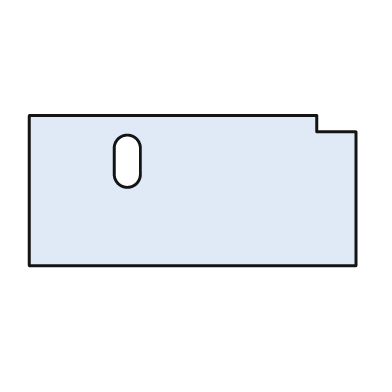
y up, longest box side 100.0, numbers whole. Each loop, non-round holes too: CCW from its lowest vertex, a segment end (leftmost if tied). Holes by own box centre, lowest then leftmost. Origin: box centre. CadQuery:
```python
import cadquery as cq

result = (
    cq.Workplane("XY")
    .moveTo(-50.0, -23.0)
    .lineTo(50.0, -23.0)
    .lineTo(50.0, 18.0)
    .lineTo(38.0, 18.0)
    .lineTo(38.0, 23.0)
    .lineTo(-50.0, 23.0)
    .close()
    .moveTo(-24.0, 5.0)
    .threePointArc((-20.0, 1.0), (-16.0, 5.0))
    .lineTo(-16.0, 13.0)
    .threePointArc((-20.0, 17.0), (-24.0, 13.0))
    .close()
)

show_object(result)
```